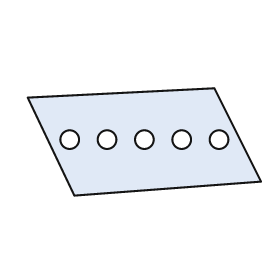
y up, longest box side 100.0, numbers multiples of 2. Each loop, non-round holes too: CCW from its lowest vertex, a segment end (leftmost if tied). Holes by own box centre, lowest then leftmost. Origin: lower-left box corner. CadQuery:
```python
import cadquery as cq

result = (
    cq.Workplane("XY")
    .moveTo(20.0, 0.0)
    .lineTo(100.0, 6.0)
    .lineTo(80.0, 46.0)
    .lineTo(0.0, 42.0)
    .close()
    .moveTo(18.0, 24.0)
    .circle(4.0)
    .moveTo(34.0, 24.0)
    .circle(4.0)
    .moveTo(50.0, 24.0)
    .circle(4.0)
    .moveTo(66.0, 24.0)
    .circle(4.0)
    .moveTo(82.0, 24.0)
    .circle(4.0)
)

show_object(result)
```